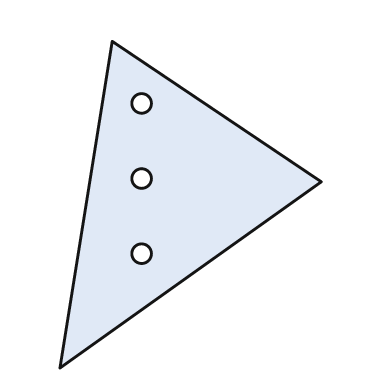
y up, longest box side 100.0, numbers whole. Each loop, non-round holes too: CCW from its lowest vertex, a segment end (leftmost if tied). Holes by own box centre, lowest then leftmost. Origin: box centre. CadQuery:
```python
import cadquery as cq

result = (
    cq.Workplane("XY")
    .moveTo(-40.0, -50.0)
    .lineTo(40.0, 7.0)
    .lineTo(-24.0, 50.0)
    .close()
    .moveTo(-15.0, -15.0)
    .circle(3.0)
    .moveTo(-15.0, 8.0)
    .circle(3.0)
    .moveTo(-15.0, 31.0)
    .circle(3.0)
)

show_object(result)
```